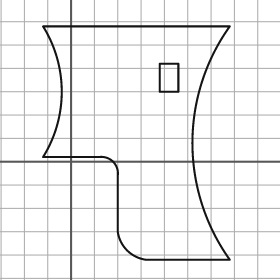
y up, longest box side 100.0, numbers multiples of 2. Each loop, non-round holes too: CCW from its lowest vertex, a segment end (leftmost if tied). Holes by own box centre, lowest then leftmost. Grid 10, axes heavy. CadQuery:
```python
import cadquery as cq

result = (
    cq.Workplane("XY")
    .moveTo(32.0, -42.0)
    .lineTo(68.0, -42.0)
    .threePointArc((52.0, 8.0), (68.0, 58.0))
    .lineTo(-12.0, 58.0)
    .threePointArc((-4.0, 30.0), (-12.0, 2.0))
    .lineTo(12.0, 2.0)
    .threePointArc((18.0, 0.0), (20.0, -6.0))
    .lineTo(20.0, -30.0)
    .threePointArc((24.0, -38.0), (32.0, -42.0))
    .close()
    .moveTo(38.0, 30.0)
    .lineTo(46.0, 30.0)
    .lineTo(46.0, 42.0)
    .lineTo(38.0, 42.0)
    .close()
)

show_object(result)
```